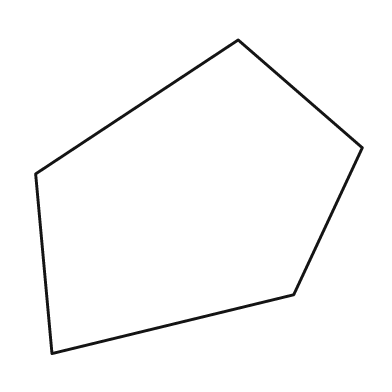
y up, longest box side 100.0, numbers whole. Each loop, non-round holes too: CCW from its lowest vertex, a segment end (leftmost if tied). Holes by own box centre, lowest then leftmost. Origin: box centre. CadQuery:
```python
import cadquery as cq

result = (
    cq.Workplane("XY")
    .moveTo(-45.0, -48.0)
    .lineTo(29.0, -30.0)
    .lineTo(50.0, 15.0)
    .lineTo(12.0, 48.0)
    .lineTo(-50.0, 7.0)
    .close()
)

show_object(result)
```